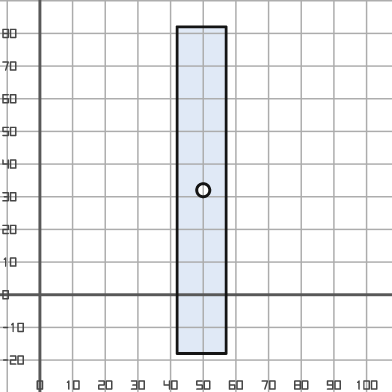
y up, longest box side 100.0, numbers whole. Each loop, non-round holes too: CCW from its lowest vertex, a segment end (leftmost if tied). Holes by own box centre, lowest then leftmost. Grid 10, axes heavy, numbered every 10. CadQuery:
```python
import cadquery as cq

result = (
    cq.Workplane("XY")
    .moveTo(42.0, -18.0)
    .lineTo(57.0, -18.0)
    .lineTo(57.0, 82.0)
    .lineTo(42.0, 82.0)
    .close()
    .moveTo(50.0, 32.0)
    .circle(2.0)
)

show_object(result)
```